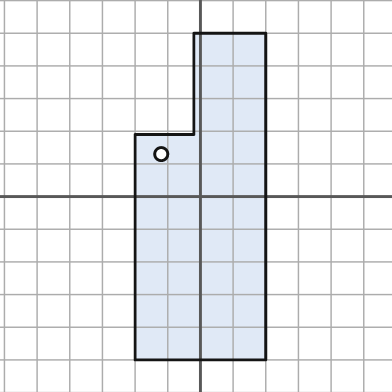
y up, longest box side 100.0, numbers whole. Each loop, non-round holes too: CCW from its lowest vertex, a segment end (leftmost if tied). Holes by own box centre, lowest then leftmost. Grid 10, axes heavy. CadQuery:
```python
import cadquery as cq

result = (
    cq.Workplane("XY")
    .moveTo(-20.0, -50.0)
    .lineTo(20.0, -50.0)
    .lineTo(20.0, 50.0)
    .lineTo(-2.0, 50.0)
    .lineTo(-2.0, 19.0)
    .lineTo(-20.0, 19.0)
    .close()
    .moveTo(-12.0, 13.0)
    .circle(2.0)
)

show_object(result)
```